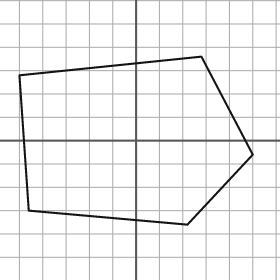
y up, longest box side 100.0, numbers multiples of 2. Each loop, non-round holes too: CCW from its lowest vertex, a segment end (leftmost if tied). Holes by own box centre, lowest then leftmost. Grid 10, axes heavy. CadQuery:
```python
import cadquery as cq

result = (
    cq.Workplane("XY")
    .moveTo(22.0, -36.0)
    .lineTo(50.0, -6.0)
    .lineTo(28.0, 36.0)
    .lineTo(-50.0, 28.0)
    .lineTo(-46.0, -30.0)
    .close()
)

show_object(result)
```